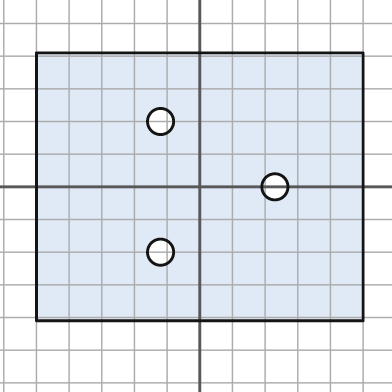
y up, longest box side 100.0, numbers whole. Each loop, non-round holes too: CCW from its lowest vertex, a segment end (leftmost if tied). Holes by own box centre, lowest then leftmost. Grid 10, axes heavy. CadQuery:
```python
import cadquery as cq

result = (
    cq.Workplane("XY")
    .moveTo(-50.0, -41.0)
    .lineTo(50.0, -41.0)
    .lineTo(50.0, 41.0)
    .lineTo(-50.0, 41.0)
    .close()
    .moveTo(-12.0, -20.0)
    .circle(4.0)
    .moveTo(23.0, 0.0)
    .circle(4.0)
    .moveTo(-12.0, 20.0)
    .circle(4.0)
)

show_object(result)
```